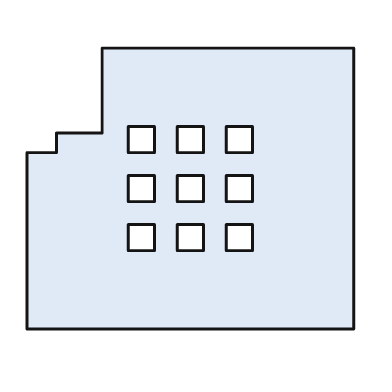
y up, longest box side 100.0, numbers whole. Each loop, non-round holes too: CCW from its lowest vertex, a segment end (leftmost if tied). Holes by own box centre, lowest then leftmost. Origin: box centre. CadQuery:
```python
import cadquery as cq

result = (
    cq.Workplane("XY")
    .moveTo(-50.0, -43.0)
    .lineTo(50.0, -43.0)
    .lineTo(50.0, 43.0)
    .lineTo(-27.0, 43.0)
    .lineTo(-27.0, 17.0)
    .lineTo(-41.0, 17.0)
    .lineTo(-41.0, 11.0)
    .lineTo(-50.0, 11.0)
    .close()
    .moveTo(-19.0, -19.0)
    .lineTo(-11.0, -19.0)
    .lineTo(-11.0, -11.0)
    .lineTo(-19.0, -11.0)
    .close()
    .moveTo(-4.0, -19.0)
    .lineTo(4.0, -19.0)
    .lineTo(4.0, -11.0)
    .lineTo(-4.0, -11.0)
    .close()
    .moveTo(11.0, -19.0)
    .lineTo(19.0, -19.0)
    .lineTo(19.0, -11.0)
    .lineTo(11.0, -11.0)
    .close()
    .moveTo(-19.0, -4.0)
    .lineTo(-11.0, -4.0)
    .lineTo(-11.0, 4.0)
    .lineTo(-19.0, 4.0)
    .close()
    .moveTo(-4.0, -4.0)
    .lineTo(4.0, -4.0)
    .lineTo(4.0, 4.0)
    .lineTo(-4.0, 4.0)
    .close()
    .moveTo(11.0, -4.0)
    .lineTo(19.0, -4.0)
    .lineTo(19.0, 4.0)
    .lineTo(11.0, 4.0)
    .close()
    .moveTo(-19.0, 11.0)
    .lineTo(-11.0, 11.0)
    .lineTo(-11.0, 19.0)
    .lineTo(-19.0, 19.0)
    .close()
    .moveTo(-4.0, 11.0)
    .lineTo(4.0, 11.0)
    .lineTo(4.0, 19.0)
    .lineTo(-4.0, 19.0)
    .close()
    .moveTo(11.0, 11.0)
    .lineTo(19.0, 11.0)
    .lineTo(19.0, 19.0)
    .lineTo(11.0, 19.0)
    .close()
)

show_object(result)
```